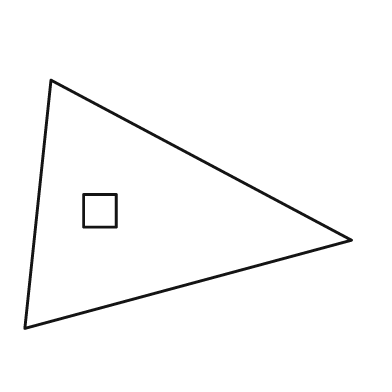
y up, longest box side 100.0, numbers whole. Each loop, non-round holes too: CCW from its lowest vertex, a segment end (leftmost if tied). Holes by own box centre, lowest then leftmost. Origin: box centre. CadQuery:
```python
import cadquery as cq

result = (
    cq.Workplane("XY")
    .moveTo(-50.0, -38.0)
    .lineTo(50.0, -11.0)
    .lineTo(-42.0, 38.0)
    .close()
    .moveTo(-32.0, -7.0)
    .lineTo(-22.0, -7.0)
    .lineTo(-22.0, 3.0)
    .lineTo(-32.0, 3.0)
    .close()
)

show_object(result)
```